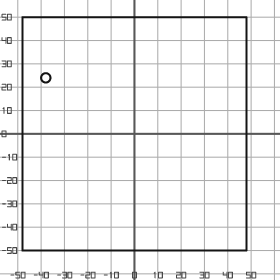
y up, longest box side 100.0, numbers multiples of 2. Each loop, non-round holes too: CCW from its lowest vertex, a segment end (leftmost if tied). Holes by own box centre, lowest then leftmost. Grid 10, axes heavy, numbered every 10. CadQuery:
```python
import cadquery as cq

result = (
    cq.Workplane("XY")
    .moveTo(-48.0, -50.0)
    .lineTo(48.0, -50.0)
    .lineTo(48.0, 50.0)
    .lineTo(-48.0, 50.0)
    .close()
    .moveTo(-38.0, 24.0)
    .circle(2.0)
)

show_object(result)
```